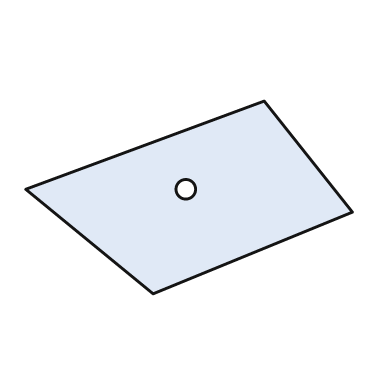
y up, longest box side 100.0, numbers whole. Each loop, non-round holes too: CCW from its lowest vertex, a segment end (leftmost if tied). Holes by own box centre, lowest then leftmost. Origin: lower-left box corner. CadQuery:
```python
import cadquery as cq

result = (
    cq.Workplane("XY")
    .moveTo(39.0, 0.0)
    .lineTo(100.0, 25.0)
    .lineTo(73.0, 59.0)
    .lineTo(0.0, 32.0)
    .close()
    .moveTo(49.0, 32.0)
    .circle(3.0)
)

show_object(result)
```